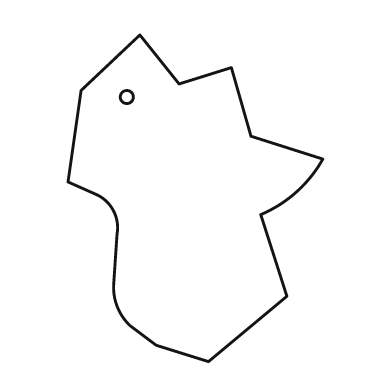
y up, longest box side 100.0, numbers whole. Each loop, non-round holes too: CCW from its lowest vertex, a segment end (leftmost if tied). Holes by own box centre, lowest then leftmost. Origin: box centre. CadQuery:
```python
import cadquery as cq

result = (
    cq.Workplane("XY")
    .moveTo(4.0, -50.0)
    .lineTo(28.0, -30.0)
    .lineTo(20.0, -5.0)
    .threePointArc((31.0, 2.0), (39.0, 12.0))
    .lineTo(17.0, 19.0)
    .lineTo(11.0, 40.0)
    .lineTo(-5.0, 35.0)
    .lineTo(-17.0, 50.0)
    .lineTo(-35.0, 33.0)
    .lineTo(-39.0, 5.0)
    .lineTo(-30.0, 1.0)
    .threePointArc((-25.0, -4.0), (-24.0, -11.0))
    .lineTo(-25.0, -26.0)
    .threePointArc((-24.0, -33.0), (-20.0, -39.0))
    .lineTo(-12.0, -45.0)
    .close()
    .moveTo(-21.0, 31.0)
    .circle(2.0)
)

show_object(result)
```